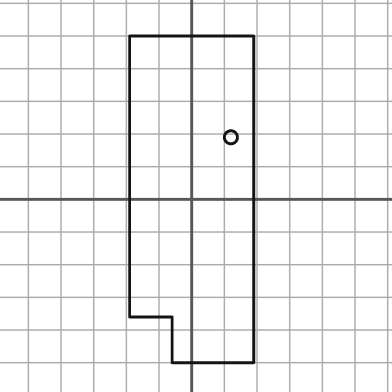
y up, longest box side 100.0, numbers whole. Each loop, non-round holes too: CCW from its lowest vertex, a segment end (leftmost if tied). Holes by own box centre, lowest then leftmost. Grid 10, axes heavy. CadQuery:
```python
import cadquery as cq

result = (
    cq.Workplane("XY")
    .moveTo(-6.0, -50.0)
    .lineTo(19.0, -50.0)
    .lineTo(19.0, 50.0)
    .lineTo(-19.0, 50.0)
    .lineTo(-19.0, -36.0)
    .lineTo(-6.0, -36.0)
    .close()
    .moveTo(12.0, 19.0)
    .circle(2.0)
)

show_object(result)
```